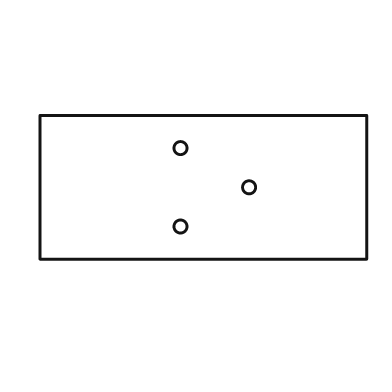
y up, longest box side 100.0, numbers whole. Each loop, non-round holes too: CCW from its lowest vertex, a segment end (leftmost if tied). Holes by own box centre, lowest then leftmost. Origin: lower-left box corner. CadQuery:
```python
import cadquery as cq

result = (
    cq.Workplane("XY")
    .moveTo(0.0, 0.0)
    .lineTo(100.0, 0.0)
    .lineTo(100.0, 44.0)
    .lineTo(0.0, 44.0)
    .close()
    .moveTo(43.0, 10.0)
    .circle(2.0)
    .moveTo(64.0, 22.0)
    .circle(2.0)
    .moveTo(43.0, 34.0)
    .circle(2.0)
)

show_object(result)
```